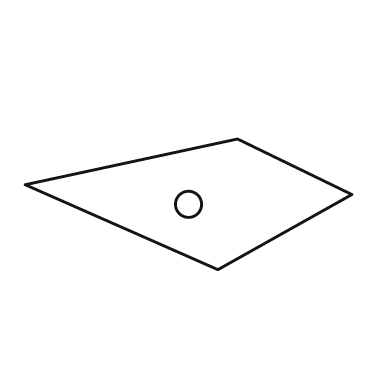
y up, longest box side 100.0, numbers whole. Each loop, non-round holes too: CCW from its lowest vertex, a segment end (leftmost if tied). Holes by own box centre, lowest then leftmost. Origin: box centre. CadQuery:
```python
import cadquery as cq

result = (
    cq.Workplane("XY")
    .moveTo(9.0, -20.0)
    .lineTo(50.0, 3.0)
    .lineTo(15.0, 20.0)
    .lineTo(-50.0, 6.0)
    .close()
    .moveTo(0.0, 0.0)
    .circle(4.0)
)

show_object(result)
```